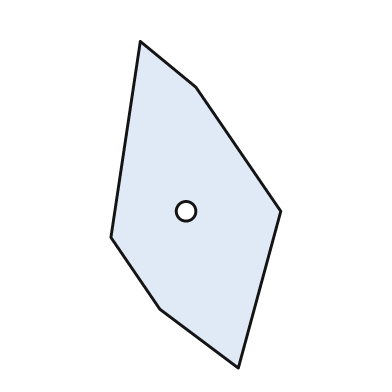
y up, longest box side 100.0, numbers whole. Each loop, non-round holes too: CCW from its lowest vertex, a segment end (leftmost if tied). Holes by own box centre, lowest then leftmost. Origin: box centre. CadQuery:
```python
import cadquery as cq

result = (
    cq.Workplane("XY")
    .moveTo(13.0, -50.0)
    .lineTo(26.0, -2.0)
    .lineTo(0.0, 36.0)
    .lineTo(-17.0, 50.0)
    .lineTo(-26.0, -10.0)
    .lineTo(-11.0, -32.0)
    .close()
    .moveTo(-3.0, -2.0)
    .circle(3.0)
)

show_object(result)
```